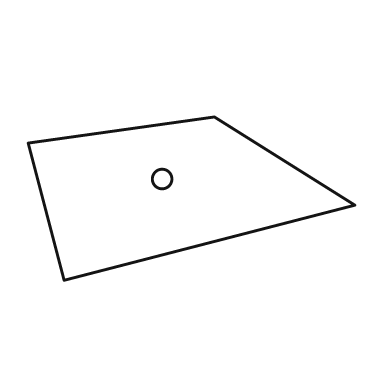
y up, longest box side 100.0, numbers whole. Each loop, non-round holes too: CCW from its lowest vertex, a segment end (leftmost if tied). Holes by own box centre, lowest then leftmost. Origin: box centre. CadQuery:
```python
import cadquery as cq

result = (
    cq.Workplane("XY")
    .moveTo(-39.0, -25.0)
    .lineTo(50.0, -2.0)
    .lineTo(7.0, 25.0)
    .lineTo(-50.0, 17.0)
    .close()
    .moveTo(-9.0, 6.0)
    .circle(3.0)
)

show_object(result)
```